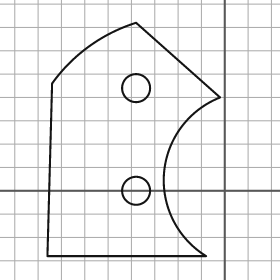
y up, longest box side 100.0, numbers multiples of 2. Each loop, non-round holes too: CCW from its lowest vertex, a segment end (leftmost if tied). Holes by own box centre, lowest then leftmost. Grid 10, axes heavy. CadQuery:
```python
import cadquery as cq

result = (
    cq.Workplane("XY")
    .moveTo(-76.0, -28.0)
    .lineTo(-8.0, -28.0)
    .threePointArc((-26.0, 8.0), (-2.0, 40.0))
    .lineTo(-38.0, 72.0)
    .threePointArc((-58.0, 62.0), (-74.0, 46.0))
    .close()
    .moveTo(-38.0, 0.0)
    .circle(6.0)
    .moveTo(-38.0, 44.0)
    .circle(6.0)
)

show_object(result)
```